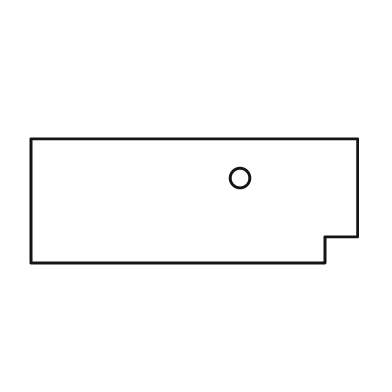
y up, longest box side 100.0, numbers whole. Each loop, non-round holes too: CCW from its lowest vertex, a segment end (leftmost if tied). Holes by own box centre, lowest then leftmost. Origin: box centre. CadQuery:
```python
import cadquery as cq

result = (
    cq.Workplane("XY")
    .moveTo(-50.0, -19.0)
    .lineTo(40.0, -19.0)
    .lineTo(40.0, -11.0)
    .lineTo(50.0, -11.0)
    .lineTo(50.0, 19.0)
    .lineTo(-50.0, 19.0)
    .close()
    .moveTo(14.0, 7.0)
    .circle(3.0)
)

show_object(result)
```